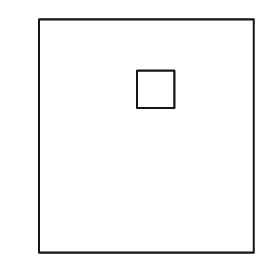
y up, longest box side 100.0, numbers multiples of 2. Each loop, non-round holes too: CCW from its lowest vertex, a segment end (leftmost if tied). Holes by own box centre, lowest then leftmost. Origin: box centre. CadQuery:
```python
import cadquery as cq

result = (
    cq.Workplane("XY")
    .moveTo(-46.0, -50.0)
    .lineTo(46.0, -50.0)
    .lineTo(46.0, 50.0)
    .lineTo(-46.0, 50.0)
    .close()
    .moveTo(-4.0, 12.0)
    .lineTo(12.0, 12.0)
    .lineTo(12.0, 28.0)
    .lineTo(-4.0, 28.0)
    .close()
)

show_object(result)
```